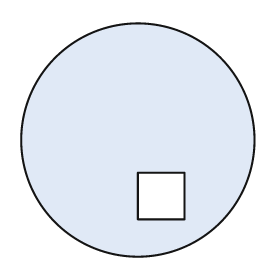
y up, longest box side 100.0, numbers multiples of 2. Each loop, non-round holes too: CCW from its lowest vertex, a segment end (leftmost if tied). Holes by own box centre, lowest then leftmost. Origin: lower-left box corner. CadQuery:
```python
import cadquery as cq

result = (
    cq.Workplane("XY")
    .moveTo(50.0, 50.0)
    .circle(50.0)
    .moveTo(50.0, 16.0)
    .lineTo(70.0, 16.0)
    .lineTo(70.0, 36.0)
    .lineTo(50.0, 36.0)
    .close()
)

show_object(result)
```